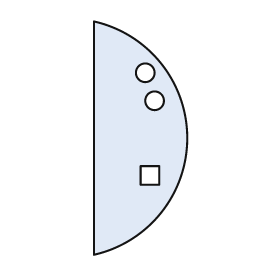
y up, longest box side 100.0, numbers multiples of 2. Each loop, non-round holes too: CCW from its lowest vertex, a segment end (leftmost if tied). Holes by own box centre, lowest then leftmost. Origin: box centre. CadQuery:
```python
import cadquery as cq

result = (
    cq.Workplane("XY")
    .moveTo(-20.0, -50.0)
    .threePointArc((20.0, 0.0), (-20.0, 50.0))
    .close()
    .moveTo(0.0, -20.0)
    .lineTo(8.0, -20.0)
    .lineTo(8.0, -12.0)
    .lineTo(0.0, -12.0)
    .close()
    .moveTo(6.0, 16.0)
    .circle(4.0)
    .moveTo(2.0, 28.0)
    .circle(4.0)
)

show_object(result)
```